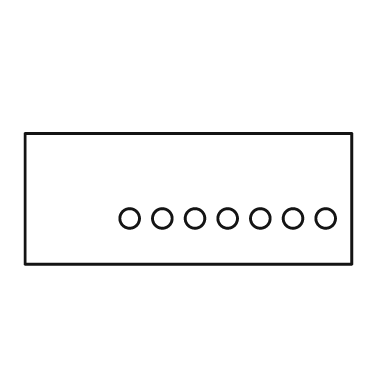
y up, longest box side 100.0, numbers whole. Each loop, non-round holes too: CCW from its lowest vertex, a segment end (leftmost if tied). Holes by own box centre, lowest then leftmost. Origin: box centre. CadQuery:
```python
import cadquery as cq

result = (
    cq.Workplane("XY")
    .moveTo(-50.0, -20.0)
    .lineTo(50.0, -20.0)
    .lineTo(50.0, 20.0)
    .lineTo(-50.0, 20.0)
    .close()
    .moveTo(-18.0, -6.0)
    .circle(3.0)
    .moveTo(-8.0, -6.0)
    .circle(3.0)
    .moveTo(2.0, -6.0)
    .circle(3.0)
    .moveTo(12.0, -6.0)
    .circle(3.0)
    .moveTo(22.0, -6.0)
    .circle(3.0)
    .moveTo(32.0, -6.0)
    .circle(3.0)
    .moveTo(42.0, -6.0)
    .circle(3.0)
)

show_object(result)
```